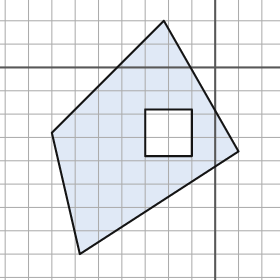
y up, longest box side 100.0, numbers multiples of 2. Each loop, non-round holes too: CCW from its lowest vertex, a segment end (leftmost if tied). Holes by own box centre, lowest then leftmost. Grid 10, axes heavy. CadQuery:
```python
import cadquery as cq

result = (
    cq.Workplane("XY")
    .moveTo(-58.0, -80.0)
    .lineTo(10.0, -36.0)
    .lineTo(-22.0, 20.0)
    .lineTo(-70.0, -28.0)
    .close()
    .moveTo(-30.0, -38.0)
    .lineTo(-10.0, -38.0)
    .lineTo(-10.0, -18.0)
    .lineTo(-30.0, -18.0)
    .close()
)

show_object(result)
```